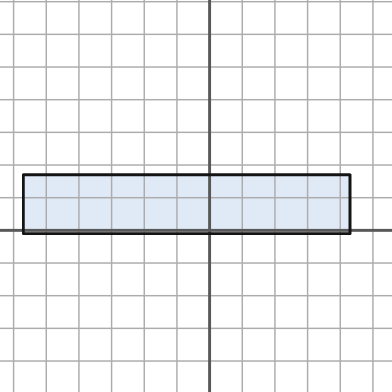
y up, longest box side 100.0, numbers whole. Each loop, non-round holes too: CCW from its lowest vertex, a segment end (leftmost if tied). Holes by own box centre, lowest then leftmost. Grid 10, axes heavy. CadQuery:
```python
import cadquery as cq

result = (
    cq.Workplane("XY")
    .moveTo(-57.0, -1.0)
    .lineTo(43.0, -1.0)
    .lineTo(43.0, 17.0)
    .lineTo(-57.0, 17.0)
    .close()
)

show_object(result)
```